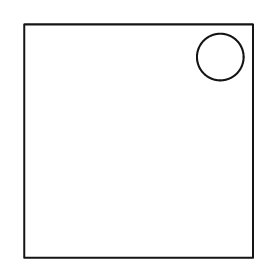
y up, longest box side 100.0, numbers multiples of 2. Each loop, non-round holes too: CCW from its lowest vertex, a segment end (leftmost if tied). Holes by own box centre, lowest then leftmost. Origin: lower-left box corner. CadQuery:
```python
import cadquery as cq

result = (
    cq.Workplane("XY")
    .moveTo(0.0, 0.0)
    .lineTo(98.0, 0.0)
    .lineTo(98.0, 100.0)
    .lineTo(0.0, 100.0)
    .close()
    .moveTo(84.0, 86.0)
    .circle(10.0)
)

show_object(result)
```